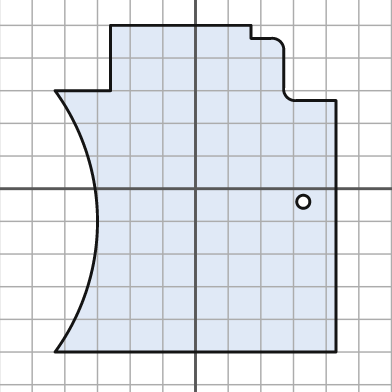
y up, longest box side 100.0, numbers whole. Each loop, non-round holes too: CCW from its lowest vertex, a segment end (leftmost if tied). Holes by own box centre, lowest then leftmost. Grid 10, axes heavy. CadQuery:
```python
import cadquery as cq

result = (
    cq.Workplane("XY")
    .moveTo(-43.0, -50.0)
    .lineTo(43.0, -50.0)
    .lineTo(43.0, 27.0)
    .lineTo(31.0, 27.0)
    .threePointArc((28.0, 28.0), (27.0, 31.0))
    .lineTo(27.0, 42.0)
    .threePointArc((26.0, 45.0), (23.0, 46.0))
    .lineTo(17.0, 46.0)
    .lineTo(17.0, 50.0)
    .lineTo(-26.0, 50.0)
    .lineTo(-26.0, 30.0)
    .lineTo(-43.0, 30.0)
    .threePointArc((-30.0, -10.0), (-43.0, -50.0))
    .close()
    .moveTo(33.0, -4.0)
    .circle(2.0)
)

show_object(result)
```